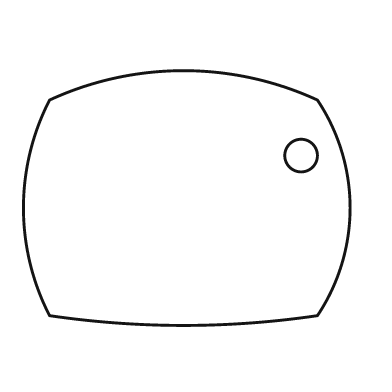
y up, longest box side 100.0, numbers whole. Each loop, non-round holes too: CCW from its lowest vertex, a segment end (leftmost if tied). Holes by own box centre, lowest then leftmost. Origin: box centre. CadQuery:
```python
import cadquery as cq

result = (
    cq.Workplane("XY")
    .moveTo(-42.0, -36.0)
    .threePointArc((-1.0, -39.0), (40.0, -36.0))
    .threePointArc((50.0, -3.0), (40.0, 30.0))
    .threePointArc((-1.0, 39.0), (-42.0, 30.0))
    .threePointArc((-50.0, -3.0), (-42.0, -36.0))
    .close()
    .moveTo(35.0, 13.0)
    .circle(5.0)
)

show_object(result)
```